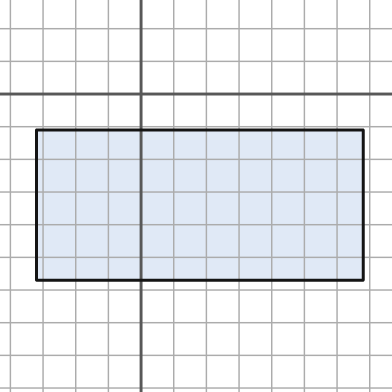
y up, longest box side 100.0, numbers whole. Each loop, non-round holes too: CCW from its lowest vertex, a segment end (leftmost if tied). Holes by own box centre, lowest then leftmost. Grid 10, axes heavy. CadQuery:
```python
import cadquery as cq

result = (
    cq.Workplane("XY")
    .moveTo(-32.0, -57.0)
    .lineTo(68.0, -57.0)
    .lineTo(68.0, -11.0)
    .lineTo(-32.0, -11.0)
    .close()
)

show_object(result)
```